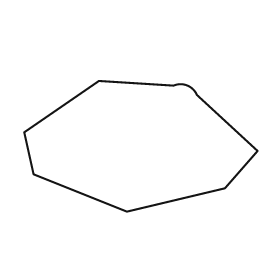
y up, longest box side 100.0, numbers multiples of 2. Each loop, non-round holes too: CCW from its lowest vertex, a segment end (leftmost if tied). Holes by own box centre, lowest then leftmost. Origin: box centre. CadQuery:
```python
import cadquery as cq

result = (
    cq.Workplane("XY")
    .moveTo(-6.0, -28.0)
    .lineTo(36.0, -18.0)
    .lineTo(50.0, -2.0)
    .lineTo(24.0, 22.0)
    .threePointArc((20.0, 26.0), (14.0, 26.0))
    .lineTo(-18.0, 28.0)
    .lineTo(-50.0, 6.0)
    .lineTo(-46.0, -12.0)
    .close()
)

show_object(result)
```